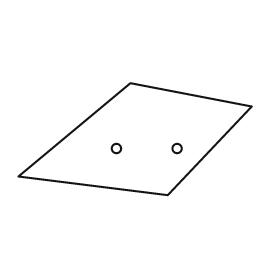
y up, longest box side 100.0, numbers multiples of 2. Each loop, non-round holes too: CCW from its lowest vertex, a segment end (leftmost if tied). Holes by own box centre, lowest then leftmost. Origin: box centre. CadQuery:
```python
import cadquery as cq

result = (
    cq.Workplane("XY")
    .moveTo(14.0, -24.0)
    .lineTo(50.0, 14.0)
    .lineTo(-2.0, 24.0)
    .lineTo(-50.0, -16.0)
    .close()
    .moveTo(-8.0, -4.0)
    .circle(2.0)
    .moveTo(18.0, -4.0)
    .circle(2.0)
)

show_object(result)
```